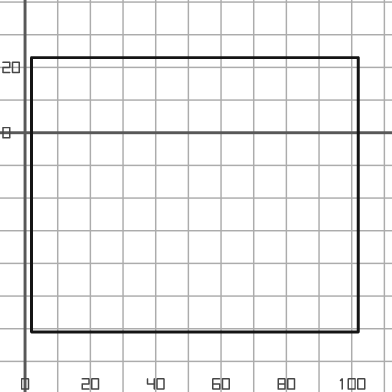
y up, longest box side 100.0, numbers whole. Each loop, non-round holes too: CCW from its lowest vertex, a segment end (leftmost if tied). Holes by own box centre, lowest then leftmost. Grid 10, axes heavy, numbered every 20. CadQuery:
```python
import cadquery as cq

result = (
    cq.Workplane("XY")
    .moveTo(2.0, -61.0)
    .lineTo(102.0, -61.0)
    .lineTo(102.0, 23.0)
    .lineTo(2.0, 23.0)
    .close()
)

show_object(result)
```